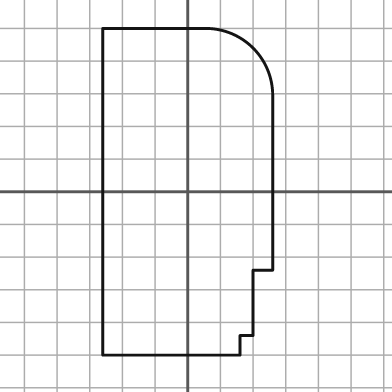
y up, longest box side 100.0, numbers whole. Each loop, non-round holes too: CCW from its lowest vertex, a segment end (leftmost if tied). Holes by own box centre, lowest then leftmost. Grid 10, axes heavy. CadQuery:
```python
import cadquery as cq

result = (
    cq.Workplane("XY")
    .moveTo(-26.0, -50.0)
    .lineTo(16.0, -50.0)
    .lineTo(16.0, -44.0)
    .lineTo(20.0, -44.0)
    .lineTo(20.0, -24.0)
    .lineTo(26.0, -24.0)
    .lineTo(26.0, 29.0)
    .threePointArc((20.0, 44.0), (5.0, 50.0))
    .lineTo(-26.0, 50.0)
    .close()
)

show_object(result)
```